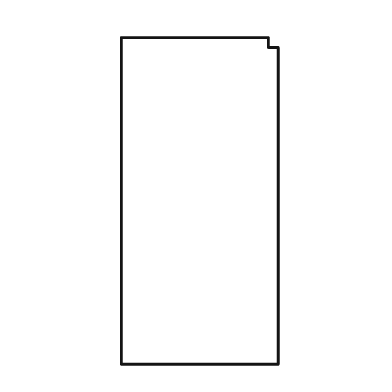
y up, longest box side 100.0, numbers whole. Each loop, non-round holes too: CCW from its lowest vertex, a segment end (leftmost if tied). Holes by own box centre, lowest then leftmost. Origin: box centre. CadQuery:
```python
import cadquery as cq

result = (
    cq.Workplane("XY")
    .moveTo(-24.0, -50.0)
    .lineTo(24.0, -50.0)
    .lineTo(24.0, 47.0)
    .lineTo(21.0, 47.0)
    .lineTo(21.0, 50.0)
    .lineTo(-24.0, 50.0)
    .close()
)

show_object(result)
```